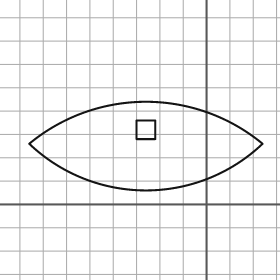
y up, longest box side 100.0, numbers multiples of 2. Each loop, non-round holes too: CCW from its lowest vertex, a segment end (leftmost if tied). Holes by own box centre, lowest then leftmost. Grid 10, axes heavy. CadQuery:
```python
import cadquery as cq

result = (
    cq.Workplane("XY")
    .moveTo(-76.0, 26.0)
    .threePointArc((-26.0, 6.0), (24.0, 26.0))
    .threePointArc((-26.0, 44.0), (-76.0, 26.0))
    .close()
    .moveTo(-30.0, 28.0)
    .lineTo(-22.0, 28.0)
    .lineTo(-22.0, 36.0)
    .lineTo(-30.0, 36.0)
    .close()
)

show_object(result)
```